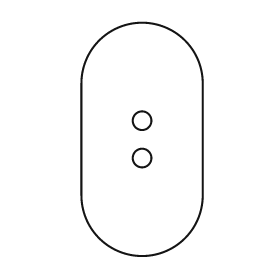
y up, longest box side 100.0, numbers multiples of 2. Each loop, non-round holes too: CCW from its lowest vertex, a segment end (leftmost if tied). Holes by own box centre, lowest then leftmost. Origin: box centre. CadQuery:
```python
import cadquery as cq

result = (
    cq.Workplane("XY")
    .moveTo(-26.0, -24.0)
    .threePointArc((0.0, -50.0), (26.0, -24.0))
    .lineTo(26.0, 24.0)
    .threePointArc((0.0, 50.0), (-26.0, 24.0))
    .close()
    .moveTo(0.0, -8.0)
    .circle(4.0)
    .moveTo(0.0, 8.0)
    .circle(4.0)
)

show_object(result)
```